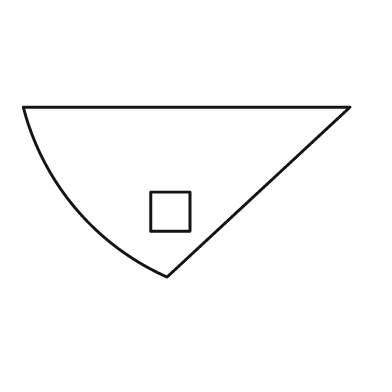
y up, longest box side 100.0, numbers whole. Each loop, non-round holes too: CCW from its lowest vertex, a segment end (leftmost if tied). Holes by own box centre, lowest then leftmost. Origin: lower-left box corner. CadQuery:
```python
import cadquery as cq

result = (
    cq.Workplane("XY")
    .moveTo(44.0, 0.0)
    .lineTo(100.0, 52.0)
    .lineTo(0.0, 52.0)
    .threePointArc((16.0, 21.0), (44.0, 0.0))
    .close()
    .moveTo(39.0, 14.0)
    .lineTo(51.0, 14.0)
    .lineTo(51.0, 26.0)
    .lineTo(39.0, 26.0)
    .close()
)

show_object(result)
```